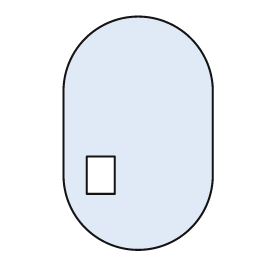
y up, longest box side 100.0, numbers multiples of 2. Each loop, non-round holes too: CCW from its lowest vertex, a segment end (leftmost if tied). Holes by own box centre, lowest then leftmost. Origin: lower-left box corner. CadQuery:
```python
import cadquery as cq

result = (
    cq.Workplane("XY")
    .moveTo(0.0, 32.0)
    .threePointArc((32.0, 0.0), (64.0, 32.0))
    .lineTo(64.0, 68.0)
    .threePointArc((32.0, 100.0), (0.0, 68.0))
    .close()
    .moveTo(10.0, 24.0)
    .lineTo(22.0, 24.0)
    .lineTo(22.0, 40.0)
    .lineTo(10.0, 40.0)
    .close()
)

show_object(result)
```